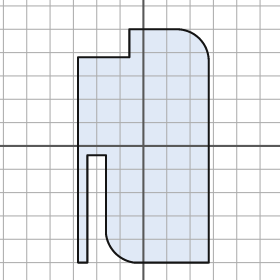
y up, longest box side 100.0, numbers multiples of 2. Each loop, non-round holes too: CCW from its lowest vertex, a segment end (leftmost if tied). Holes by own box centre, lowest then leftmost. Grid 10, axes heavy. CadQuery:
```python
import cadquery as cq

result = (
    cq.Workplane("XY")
    .moveTo(-28.0, -50.0)
    .lineTo(-24.0, -50.0)
    .lineTo(-24.0, -4.0)
    .lineTo(-16.0, -4.0)
    .lineTo(-16.0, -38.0)
    .threePointArc((-12.0, -46.0), (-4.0, -50.0))
    .lineTo(28.0, -50.0)
    .lineTo(28.0, 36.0)
    .threePointArc((24.0, 46.0), (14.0, 50.0))
    .lineTo(-6.0, 50.0)
    .lineTo(-6.0, 38.0)
    .lineTo(-28.0, 38.0)
    .close()
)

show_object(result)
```